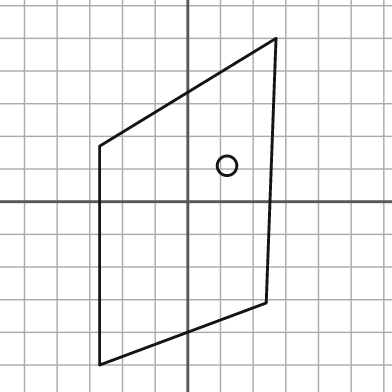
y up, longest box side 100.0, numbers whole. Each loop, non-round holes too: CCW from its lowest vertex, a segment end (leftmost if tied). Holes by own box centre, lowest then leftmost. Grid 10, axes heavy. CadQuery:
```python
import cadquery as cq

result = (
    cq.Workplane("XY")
    .moveTo(-27.0, -50.0)
    .lineTo(24.0, -31.0)
    .lineTo(27.0, 50.0)
    .lineTo(-27.0, 17.0)
    .close()
    .moveTo(12.0, 11.0)
    .circle(3.0)
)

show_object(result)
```